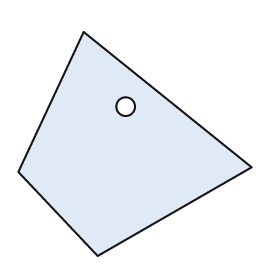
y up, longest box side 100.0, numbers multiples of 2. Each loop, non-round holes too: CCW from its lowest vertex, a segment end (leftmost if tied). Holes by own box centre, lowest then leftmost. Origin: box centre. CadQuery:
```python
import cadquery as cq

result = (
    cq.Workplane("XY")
    .moveTo(-16.0, -48.0)
    .lineTo(50.0, -10.0)
    .lineTo(-22.0, 48.0)
    .lineTo(-50.0, -12.0)
    .close()
    .moveTo(-4.0, 16.0)
    .circle(4.0)
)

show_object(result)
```